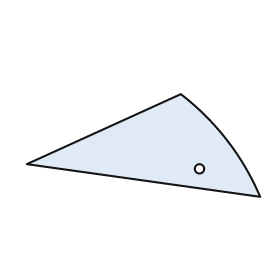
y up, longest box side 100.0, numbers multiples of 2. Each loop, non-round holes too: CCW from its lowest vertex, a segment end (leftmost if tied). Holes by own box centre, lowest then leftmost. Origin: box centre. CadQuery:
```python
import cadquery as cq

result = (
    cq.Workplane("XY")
    .moveTo(50.0, -22.0)
    .threePointArc((36.0, 2.0), (16.0, 22.0))
    .lineTo(-50.0, -8.0)
    .close()
    .moveTo(24.0, -10.0)
    .circle(2.0)
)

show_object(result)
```